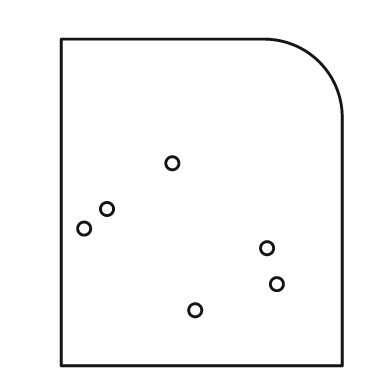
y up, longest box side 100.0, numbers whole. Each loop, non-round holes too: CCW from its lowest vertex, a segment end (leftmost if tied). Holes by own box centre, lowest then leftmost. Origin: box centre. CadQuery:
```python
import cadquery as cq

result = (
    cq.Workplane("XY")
    .moveTo(-43.0, -50.0)
    .lineTo(43.0, -50.0)
    .lineTo(43.0, 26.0)
    .threePointArc((36.0, 43.0), (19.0, 50.0))
    .lineTo(-43.0, 50.0)
    .close()
    .moveTo(-2.0, -33.0)
    .circle(2.0)
    .moveTo(23.0, -25.0)
    .circle(2.0)
    .moveTo(20.0, -14.0)
    .circle(2.0)
    .moveTo(-36.0, -8.0)
    .circle(2.0)
    .moveTo(-29.0, -2.0)
    .circle(2.0)
    .moveTo(-9.0, 12.0)
    .circle(2.0)
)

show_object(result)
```